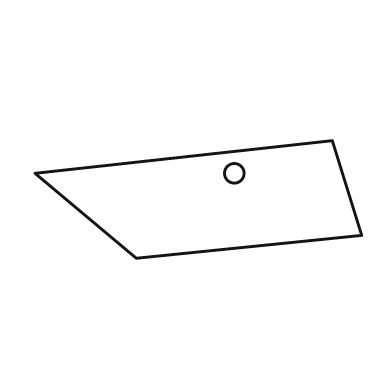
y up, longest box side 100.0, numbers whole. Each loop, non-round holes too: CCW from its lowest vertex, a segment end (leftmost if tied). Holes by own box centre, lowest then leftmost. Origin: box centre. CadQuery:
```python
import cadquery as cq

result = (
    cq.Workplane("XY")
    .moveTo(-19.0, -18.0)
    .lineTo(50.0, -11.0)
    .lineTo(41.0, 18.0)
    .lineTo(-50.0, 8.0)
    .close()
    .moveTo(11.0, 8.0)
    .circle(3.0)
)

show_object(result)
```